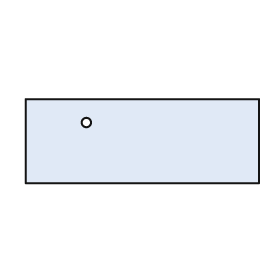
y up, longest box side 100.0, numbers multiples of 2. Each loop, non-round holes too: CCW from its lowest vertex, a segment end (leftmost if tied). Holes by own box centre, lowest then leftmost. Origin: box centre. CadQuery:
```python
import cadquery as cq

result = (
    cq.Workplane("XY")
    .moveTo(-50.0, -18.0)
    .lineTo(50.0, -18.0)
    .lineTo(50.0, 18.0)
    .lineTo(-50.0, 18.0)
    .close()
    .moveTo(-24.0, 8.0)
    .circle(2.0)
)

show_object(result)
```